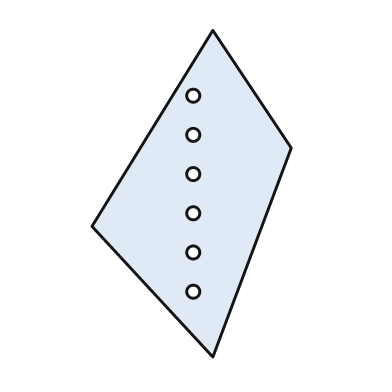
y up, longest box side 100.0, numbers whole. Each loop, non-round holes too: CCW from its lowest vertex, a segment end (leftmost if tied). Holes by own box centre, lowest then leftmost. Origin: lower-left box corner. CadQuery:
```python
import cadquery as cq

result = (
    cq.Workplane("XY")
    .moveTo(37.0, 0.0)
    .lineTo(61.0, 64.0)
    .lineTo(37.0, 100.0)
    .lineTo(0.0, 40.0)
    .close()
    .moveTo(31.0, 20.0)
    .circle(2.0)
    .moveTo(31.0, 32.0)
    .circle(2.0)
    .moveTo(31.0, 44.0)
    .circle(2.0)
    .moveTo(31.0, 56.0)
    .circle(2.0)
    .moveTo(31.0, 68.0)
    .circle(2.0)
    .moveTo(31.0, 80.0)
    .circle(2.0)
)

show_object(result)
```